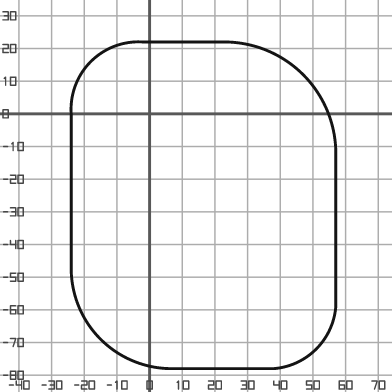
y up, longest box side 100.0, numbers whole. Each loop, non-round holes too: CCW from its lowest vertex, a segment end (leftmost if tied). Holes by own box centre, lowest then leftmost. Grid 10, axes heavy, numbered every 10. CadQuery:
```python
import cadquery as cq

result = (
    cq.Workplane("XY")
    .moveTo(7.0, -78.0)
    .lineTo(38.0, -78.0)
    .threePointArc((51.0, -72.0), (57.0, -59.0))
    .lineTo(57.0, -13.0)
    .threePointArc((47.0, 12.0), (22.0, 22.0))
    .lineTo(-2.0, 22.0)
    .threePointArc((-18.0, 16.0), (-24.0, 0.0))
    .lineTo(-24.0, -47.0)
    .threePointArc((-15.0, -69.0), (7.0, -78.0))
    .close()
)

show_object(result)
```